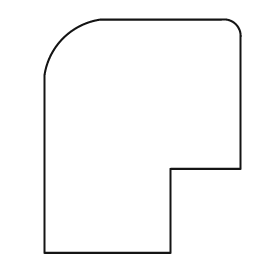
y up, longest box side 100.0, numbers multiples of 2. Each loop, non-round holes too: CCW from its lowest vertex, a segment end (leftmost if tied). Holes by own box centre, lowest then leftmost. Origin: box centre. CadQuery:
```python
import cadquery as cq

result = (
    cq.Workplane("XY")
    .moveTo(-42.0, -50.0)
    .lineTo(12.0, -50.0)
    .lineTo(12.0, -14.0)
    .lineTo(42.0, -14.0)
    .lineTo(42.0, 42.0)
    .threePointArc((40.0, 48.0), (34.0, 50.0))
    .lineTo(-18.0, 50.0)
    .threePointArc((-34.0, 42.0), (-42.0, 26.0))
    .close()
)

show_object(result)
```